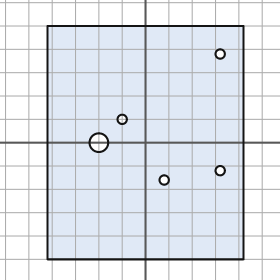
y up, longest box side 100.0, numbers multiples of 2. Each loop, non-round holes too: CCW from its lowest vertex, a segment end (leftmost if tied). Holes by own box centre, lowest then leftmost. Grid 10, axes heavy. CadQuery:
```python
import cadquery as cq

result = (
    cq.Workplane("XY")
    .moveTo(-42.0, -50.0)
    .lineTo(42.0, -50.0)
    .lineTo(42.0, 50.0)
    .lineTo(-42.0, 50.0)
    .close()
    .moveTo(8.0, -16.0)
    .circle(2.0)
    .moveTo(32.0, -12.0)
    .circle(2.0)
    .moveTo(-20.0, 0.0)
    .circle(4.0)
    .moveTo(-10.0, 10.0)
    .circle(2.0)
    .moveTo(32.0, 38.0)
    .circle(2.0)
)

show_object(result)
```